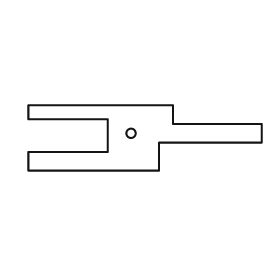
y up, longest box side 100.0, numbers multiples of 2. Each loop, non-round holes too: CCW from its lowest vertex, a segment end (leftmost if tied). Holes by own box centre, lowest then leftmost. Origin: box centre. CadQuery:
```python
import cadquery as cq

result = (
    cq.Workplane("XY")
    .moveTo(-50.0, -14.0)
    .lineTo(6.0, -14.0)
    .lineTo(6.0, -2.0)
    .lineTo(50.0, -2.0)
    .lineTo(50.0, 6.0)
    .lineTo(12.0, 6.0)
    .lineTo(12.0, 14.0)
    .lineTo(-50.0, 14.0)
    .lineTo(-50.0, 8.0)
    .lineTo(-16.0, 8.0)
    .lineTo(-16.0, -6.0)
    .lineTo(-50.0, -6.0)
    .close()
    .moveTo(-6.0, 2.0)
    .circle(2.0)
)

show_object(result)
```